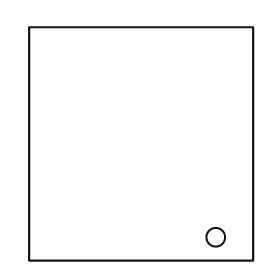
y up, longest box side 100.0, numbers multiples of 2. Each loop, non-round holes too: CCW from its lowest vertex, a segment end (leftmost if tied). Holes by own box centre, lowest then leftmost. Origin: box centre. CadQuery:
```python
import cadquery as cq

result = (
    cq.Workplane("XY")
    .moveTo(-48.0, -50.0)
    .lineTo(48.0, -50.0)
    .lineTo(48.0, 50.0)
    .lineTo(-48.0, 50.0)
    .close()
    .moveTo(32.0, -40.0)
    .circle(4.0)
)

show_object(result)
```